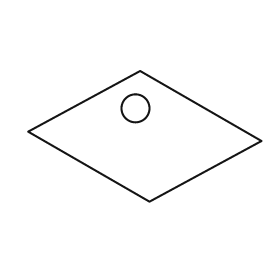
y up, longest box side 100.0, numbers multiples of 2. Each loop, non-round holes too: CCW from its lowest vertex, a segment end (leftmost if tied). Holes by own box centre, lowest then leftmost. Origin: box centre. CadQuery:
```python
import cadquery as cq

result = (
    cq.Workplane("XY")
    .moveTo(2.0, -28.0)
    .lineTo(50.0, -2.0)
    .lineTo(-2.0, 28.0)
    .lineTo(-50.0, 2.0)
    .close()
    .moveTo(-4.0, 12.0)
    .circle(6.0)
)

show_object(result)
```